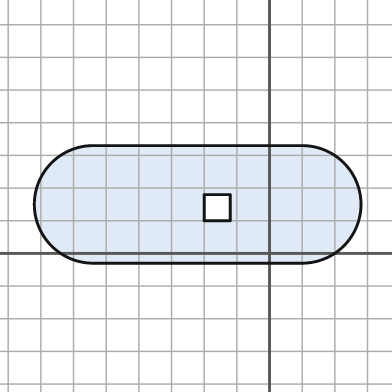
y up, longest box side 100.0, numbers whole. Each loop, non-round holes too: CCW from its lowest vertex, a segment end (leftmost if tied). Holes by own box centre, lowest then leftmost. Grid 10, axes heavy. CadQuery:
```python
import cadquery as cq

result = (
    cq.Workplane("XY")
    .moveTo(-54.0, -3.0)
    .lineTo(10.0, -3.0)
    .threePointArc((28.0, 15.0), (10.0, 33.0))
    .lineTo(-54.0, 33.0)
    .threePointArc((-72.0, 15.0), (-54.0, -3.0))
    .close()
    .moveTo(-20.0, 10.0)
    .lineTo(-12.0, 10.0)
    .lineTo(-12.0, 18.0)
    .lineTo(-20.0, 18.0)
    .close()
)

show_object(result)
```